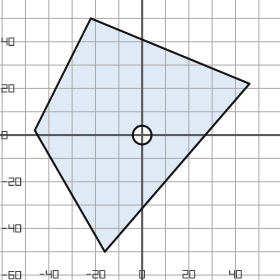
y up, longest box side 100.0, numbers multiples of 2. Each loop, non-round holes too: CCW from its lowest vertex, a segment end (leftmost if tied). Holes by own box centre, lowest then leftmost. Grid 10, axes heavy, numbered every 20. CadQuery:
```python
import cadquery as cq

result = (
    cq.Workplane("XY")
    .moveTo(-16.0, -50.0)
    .lineTo(46.0, 22.0)
    .lineTo(-22.0, 50.0)
    .lineTo(-46.0, 2.0)
    .close()
    .moveTo(0.0, 0.0)
    .circle(4.0)
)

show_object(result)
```